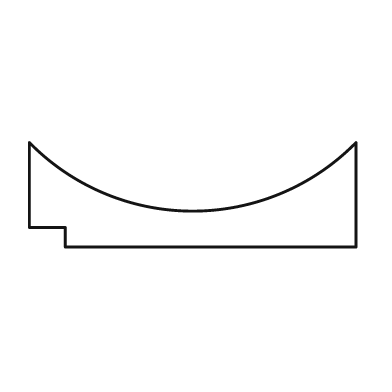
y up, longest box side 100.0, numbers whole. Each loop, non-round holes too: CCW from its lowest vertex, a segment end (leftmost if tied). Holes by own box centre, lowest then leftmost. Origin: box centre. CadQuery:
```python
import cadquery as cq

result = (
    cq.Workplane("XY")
    .moveTo(-39.0, -16.0)
    .lineTo(50.0, -16.0)
    .lineTo(50.0, 16.0)
    .threePointArc((0.0, -5.0), (-50.0, 16.0))
    .lineTo(-50.0, -10.0)
    .lineTo(-39.0, -10.0)
    .close()
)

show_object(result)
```